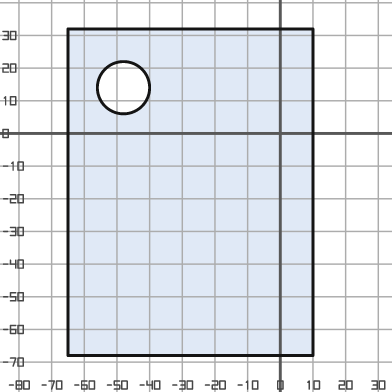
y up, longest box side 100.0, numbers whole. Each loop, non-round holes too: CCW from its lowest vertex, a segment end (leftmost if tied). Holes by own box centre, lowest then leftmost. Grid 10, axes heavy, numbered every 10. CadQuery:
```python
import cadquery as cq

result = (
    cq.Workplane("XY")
    .moveTo(-65.0, -68.0)
    .lineTo(10.0, -68.0)
    .lineTo(10.0, 32.0)
    .lineTo(-65.0, 32.0)
    .close()
    .moveTo(-48.0, 14.0)
    .circle(8.0)
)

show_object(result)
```